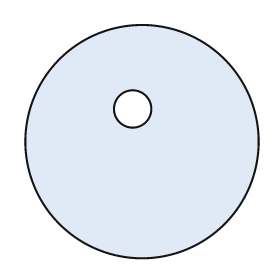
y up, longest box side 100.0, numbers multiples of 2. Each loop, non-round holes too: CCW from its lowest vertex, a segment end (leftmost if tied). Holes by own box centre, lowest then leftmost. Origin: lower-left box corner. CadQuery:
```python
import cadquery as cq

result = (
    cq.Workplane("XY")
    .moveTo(50.0, 50.0)
    .circle(50.0)
    .moveTo(46.0, 64.0)
    .circle(8.0)
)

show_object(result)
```